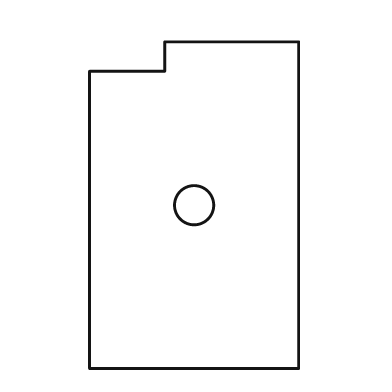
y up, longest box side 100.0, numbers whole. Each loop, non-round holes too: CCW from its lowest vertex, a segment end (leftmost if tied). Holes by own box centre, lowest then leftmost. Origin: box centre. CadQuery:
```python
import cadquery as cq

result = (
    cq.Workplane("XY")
    .moveTo(-32.0, -50.0)
    .lineTo(32.0, -50.0)
    .lineTo(32.0, 50.0)
    .lineTo(-9.0, 50.0)
    .lineTo(-9.0, 41.0)
    .lineTo(-32.0, 41.0)
    .close()
    .moveTo(0.0, 0.0)
    .circle(6.0)
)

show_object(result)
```